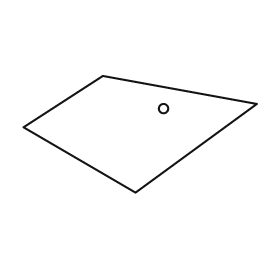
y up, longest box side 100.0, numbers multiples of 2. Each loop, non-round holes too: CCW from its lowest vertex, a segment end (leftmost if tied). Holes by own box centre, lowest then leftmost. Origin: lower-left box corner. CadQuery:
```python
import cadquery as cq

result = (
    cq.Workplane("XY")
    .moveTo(48.0, 0.0)
    .lineTo(100.0, 38.0)
    .lineTo(34.0, 50.0)
    .lineTo(0.0, 28.0)
    .close()
    .moveTo(60.0, 36.0)
    .circle(2.0)
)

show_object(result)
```